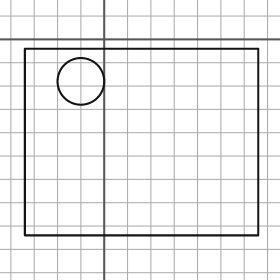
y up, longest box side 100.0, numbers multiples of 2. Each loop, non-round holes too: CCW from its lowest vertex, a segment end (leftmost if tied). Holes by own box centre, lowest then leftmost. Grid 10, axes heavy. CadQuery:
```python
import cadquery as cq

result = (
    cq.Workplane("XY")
    .moveTo(-34.0, -84.0)
    .lineTo(66.0, -84.0)
    .lineTo(66.0, -4.0)
    .lineTo(-34.0, -4.0)
    .close()
    .moveTo(-10.0, -18.0)
    .circle(10.0)
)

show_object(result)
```